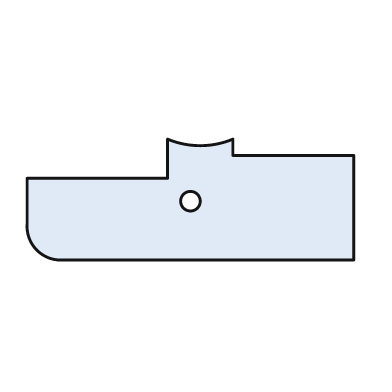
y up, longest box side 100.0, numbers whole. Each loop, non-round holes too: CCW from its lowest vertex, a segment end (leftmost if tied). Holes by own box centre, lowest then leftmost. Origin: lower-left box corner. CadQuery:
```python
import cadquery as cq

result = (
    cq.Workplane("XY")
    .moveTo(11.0, 0.0)
    .lineTo(100.0, 0.0)
    .lineTo(100.0, 32.0)
    .lineTo(63.0, 32.0)
    .lineTo(63.0, 37.0)
    .threePointArc((53.0, 35.0), (43.0, 37.0))
    .lineTo(43.0, 25.0)
    .lineTo(0.0, 25.0)
    .lineTo(0.0, 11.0)
    .threePointArc((3.0, 3.0), (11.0, 0.0))
    .close()
    .moveTo(50.0, 18.0)
    .circle(3.0)
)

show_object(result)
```